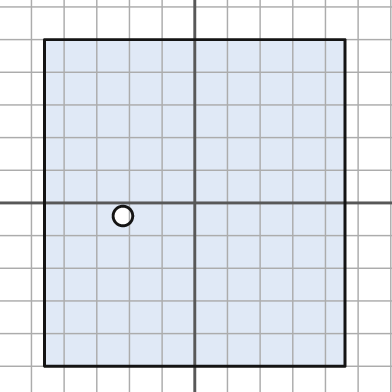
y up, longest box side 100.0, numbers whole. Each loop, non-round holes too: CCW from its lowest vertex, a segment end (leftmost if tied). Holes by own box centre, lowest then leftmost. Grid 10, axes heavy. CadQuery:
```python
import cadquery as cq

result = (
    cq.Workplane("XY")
    .moveTo(-46.0, -50.0)
    .lineTo(46.0, -50.0)
    .lineTo(46.0, 50.0)
    .lineTo(-46.0, 50.0)
    .close()
    .moveTo(-22.0, -4.0)
    .circle(3.0)
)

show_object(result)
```